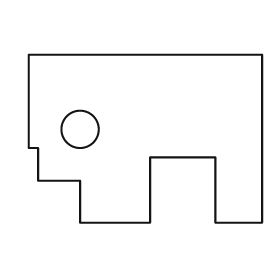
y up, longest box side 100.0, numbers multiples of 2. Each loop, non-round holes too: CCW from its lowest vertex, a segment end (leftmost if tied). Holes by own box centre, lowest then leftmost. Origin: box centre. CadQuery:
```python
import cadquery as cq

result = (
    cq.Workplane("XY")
    .moveTo(-28.0, -36.0)
    .lineTo(2.0, -36.0)
    .lineTo(2.0, -8.0)
    .lineTo(30.0, -8.0)
    .lineTo(30.0, -36.0)
    .lineTo(50.0, -36.0)
    .lineTo(50.0, 36.0)
    .lineTo(-50.0, 36.0)
    .lineTo(-50.0, -4.0)
    .lineTo(-46.0, -4.0)
    .lineTo(-46.0, -18.0)
    .lineTo(-28.0, -18.0)
    .close()
    .moveTo(-28.0, 4.0)
    .circle(8.0)
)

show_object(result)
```